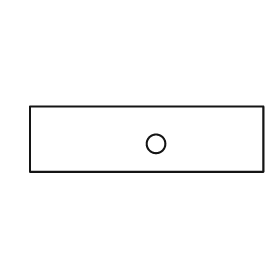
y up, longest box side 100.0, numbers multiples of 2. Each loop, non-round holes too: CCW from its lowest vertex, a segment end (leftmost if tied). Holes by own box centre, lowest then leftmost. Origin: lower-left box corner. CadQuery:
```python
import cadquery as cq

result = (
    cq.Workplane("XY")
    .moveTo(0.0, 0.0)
    .lineTo(100.0, 0.0)
    .lineTo(100.0, 28.0)
    .lineTo(0.0, 28.0)
    .close()
    .moveTo(54.0, 12.0)
    .circle(4.0)
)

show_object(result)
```